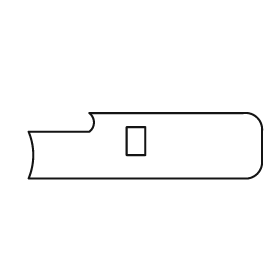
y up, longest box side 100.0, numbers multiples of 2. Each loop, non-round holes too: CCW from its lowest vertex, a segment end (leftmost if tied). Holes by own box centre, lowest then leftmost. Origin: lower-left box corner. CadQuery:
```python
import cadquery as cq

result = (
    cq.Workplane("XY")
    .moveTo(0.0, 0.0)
    .lineTo(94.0, 0.0)
    .threePointArc((98.0, 2.0), (100.0, 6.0))
    .lineTo(100.0, 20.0)
    .threePointArc((98.0, 26.0), (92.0, 28.0))
    .lineTo(26.0, 28.0)
    .threePointArc((28.0, 24.0), (26.0, 20.0))
    .lineTo(0.0, 20.0)
    .threePointArc((2.0, 10.0), (0.0, 0.0))
    .close()
    .moveTo(42.0, 10.0)
    .lineTo(50.0, 10.0)
    .lineTo(50.0, 22.0)
    .lineTo(42.0, 22.0)
    .close()
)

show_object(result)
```